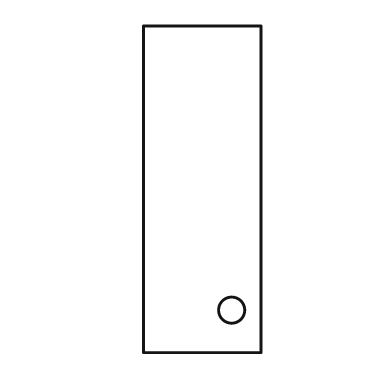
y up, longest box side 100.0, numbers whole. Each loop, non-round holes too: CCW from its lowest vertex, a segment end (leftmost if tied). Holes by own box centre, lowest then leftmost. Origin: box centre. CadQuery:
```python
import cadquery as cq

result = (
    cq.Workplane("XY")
    .moveTo(-18.0, -50.0)
    .lineTo(18.0, -50.0)
    .lineTo(18.0, 50.0)
    .lineTo(-18.0, 50.0)
    .close()
    .moveTo(9.0, -37.0)
    .circle(4.0)
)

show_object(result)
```